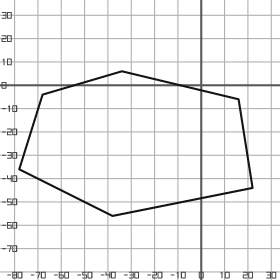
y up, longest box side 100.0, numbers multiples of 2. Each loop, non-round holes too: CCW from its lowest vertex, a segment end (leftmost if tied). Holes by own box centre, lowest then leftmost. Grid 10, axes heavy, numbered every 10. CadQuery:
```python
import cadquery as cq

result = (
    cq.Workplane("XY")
    .moveTo(-38.0, -56.0)
    .lineTo(22.0, -44.0)
    .lineTo(16.0, -6.0)
    .lineTo(-34.0, 6.0)
    .lineTo(-68.0, -4.0)
    .lineTo(-78.0, -36.0)
    .close()
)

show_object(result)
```